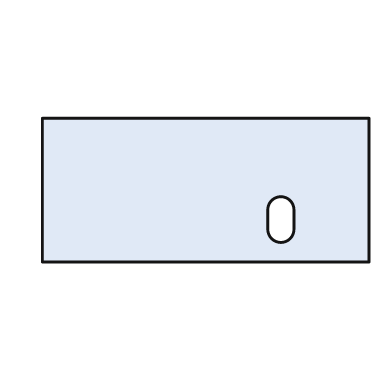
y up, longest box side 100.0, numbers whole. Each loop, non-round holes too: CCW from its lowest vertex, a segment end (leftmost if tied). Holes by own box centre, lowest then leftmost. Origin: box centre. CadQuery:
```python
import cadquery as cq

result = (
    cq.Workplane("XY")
    .moveTo(-50.0, -22.0)
    .lineTo(50.0, -22.0)
    .lineTo(50.0, 22.0)
    .lineTo(-50.0, 22.0)
    .close()
    .moveTo(19.0, -12.0)
    .threePointArc((23.0, -16.0), (27.0, -12.0))
    .lineTo(27.0, -6.0)
    .threePointArc((23.0, -2.0), (19.0, -6.0))
    .close()
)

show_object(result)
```